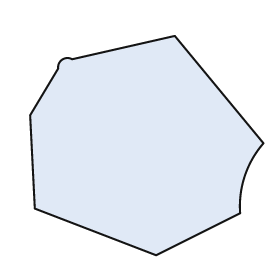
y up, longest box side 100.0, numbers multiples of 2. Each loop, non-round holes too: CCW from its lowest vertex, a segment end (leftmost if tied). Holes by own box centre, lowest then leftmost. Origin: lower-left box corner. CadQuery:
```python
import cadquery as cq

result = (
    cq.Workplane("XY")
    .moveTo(54.0, 0.0)
    .lineTo(90.0, 18.0)
    .threePointArc((92.0, 34.0), (100.0, 48.0))
    .lineTo(62.0, 94.0)
    .lineTo(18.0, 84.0)
    .threePointArc((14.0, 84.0), (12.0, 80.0))
    .lineTo(0.0, 60.0)
    .lineTo(2.0, 20.0)
    .close()
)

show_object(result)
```